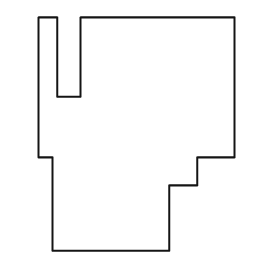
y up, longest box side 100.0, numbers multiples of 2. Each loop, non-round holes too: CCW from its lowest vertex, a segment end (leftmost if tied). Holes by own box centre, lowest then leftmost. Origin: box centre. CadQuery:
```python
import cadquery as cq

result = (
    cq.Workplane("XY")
    .moveTo(-36.0, -50.0)
    .lineTo(14.0, -50.0)
    .lineTo(14.0, -22.0)
    .lineTo(26.0, -22.0)
    .lineTo(26.0, -10.0)
    .lineTo(42.0, -10.0)
    .lineTo(42.0, 50.0)
    .lineTo(-24.0, 50.0)
    .lineTo(-24.0, 16.0)
    .lineTo(-34.0, 16.0)
    .lineTo(-34.0, 50.0)
    .lineTo(-42.0, 50.0)
    .lineTo(-42.0, -10.0)
    .lineTo(-36.0, -10.0)
    .close()
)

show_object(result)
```